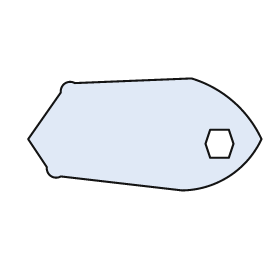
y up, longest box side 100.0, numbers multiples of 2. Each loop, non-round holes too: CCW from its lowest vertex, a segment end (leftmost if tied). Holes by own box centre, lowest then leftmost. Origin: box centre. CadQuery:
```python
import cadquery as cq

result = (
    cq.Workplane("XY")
    .moveTo(16.0, -24.0)
    .threePointArc((36.0, -18.0), (50.0, -2.0))
    .threePointArc((38.0, 14.0), (20.0, 24.0))
    .lineTo(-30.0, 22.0)
    .threePointArc((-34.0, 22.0), (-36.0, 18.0))
    .lineTo(-50.0, -2.0)
    .lineTo(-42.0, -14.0)
    .threePointArc((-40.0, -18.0), (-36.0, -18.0))
    .close()
    .moveTo(28.0, -10.0)
    .lineTo(36.0, -10.0)
    .lineTo(38.0, -4.0)
    .lineTo(36.0, 2.0)
    .lineTo(28.0, 2.0)
    .lineTo(26.0, -4.0)
    .close()
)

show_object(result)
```